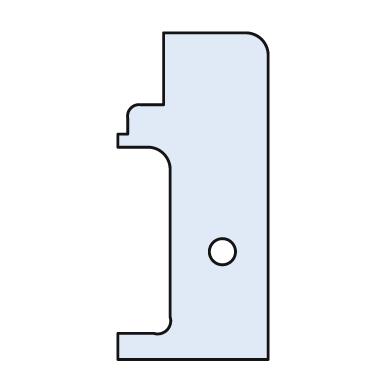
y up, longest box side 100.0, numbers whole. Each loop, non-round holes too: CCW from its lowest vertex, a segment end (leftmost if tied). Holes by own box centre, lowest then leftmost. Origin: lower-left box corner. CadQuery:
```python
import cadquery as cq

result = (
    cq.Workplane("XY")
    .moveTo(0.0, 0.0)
    .lineTo(46.0, 0.0)
    .lineTo(46.0, 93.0)
    .threePointArc((44.0, 98.0), (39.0, 100.0))
    .lineTo(14.0, 100.0)
    .lineTo(14.0, 78.0)
    .lineTo(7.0, 78.0)
    .threePointArc((4.0, 77.0), (3.0, 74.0))
    .lineTo(3.0, 69.0)
    .lineTo(0.0, 69.0)
    .lineTo(0.0, 65.0)
    .lineTo(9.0, 65.0)
    .threePointArc((14.0, 63.0), (16.0, 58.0))
    .lineTo(16.0, 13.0)
    .threePointArc((15.0, 9.0), (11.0, 8.0))
    .lineTo(0.0, 8.0)
    .close()
    .moveTo(32.0, 33.0)
    .circle(4.0)
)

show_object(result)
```